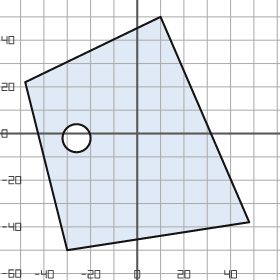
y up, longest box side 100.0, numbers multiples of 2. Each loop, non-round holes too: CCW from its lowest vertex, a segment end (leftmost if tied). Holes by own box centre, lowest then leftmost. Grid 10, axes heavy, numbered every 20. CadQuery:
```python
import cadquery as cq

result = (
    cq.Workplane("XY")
    .moveTo(-30.0, -50.0)
    .lineTo(48.0, -38.0)
    .lineTo(10.0, 50.0)
    .lineTo(-48.0, 22.0)
    .close()
    .moveTo(-26.0, -2.0)
    .circle(6.0)
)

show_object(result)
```